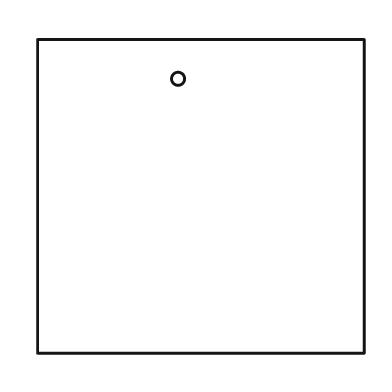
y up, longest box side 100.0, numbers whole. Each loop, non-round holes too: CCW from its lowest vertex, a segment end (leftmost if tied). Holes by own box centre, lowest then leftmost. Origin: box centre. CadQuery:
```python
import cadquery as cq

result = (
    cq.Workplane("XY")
    .moveTo(-50.0, -48.0)
    .lineTo(50.0, -48.0)
    .lineTo(50.0, 48.0)
    .lineTo(-50.0, 48.0)
    .close()
    .moveTo(-7.0, 36.0)
    .circle(2.0)
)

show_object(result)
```